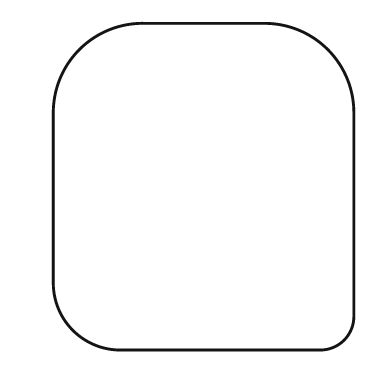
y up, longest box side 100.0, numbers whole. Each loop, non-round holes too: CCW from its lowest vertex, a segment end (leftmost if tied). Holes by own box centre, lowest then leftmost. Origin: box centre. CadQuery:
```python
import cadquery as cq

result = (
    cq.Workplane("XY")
    .moveTo(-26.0, -50.0)
    .lineTo(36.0, -50.0)
    .threePointArc((43.0, -47.0), (46.0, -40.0))
    .lineTo(46.0, 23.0)
    .threePointArc((38.0, 42.0), (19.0, 50.0))
    .lineTo(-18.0, 50.0)
    .threePointArc((-38.0, 42.0), (-46.0, 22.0))
    .lineTo(-46.0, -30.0)
    .threePointArc((-40.0, -44.0), (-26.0, -50.0))
    .close()
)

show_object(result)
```